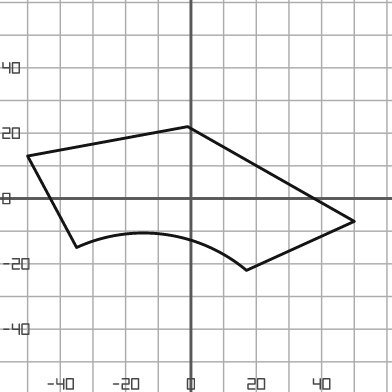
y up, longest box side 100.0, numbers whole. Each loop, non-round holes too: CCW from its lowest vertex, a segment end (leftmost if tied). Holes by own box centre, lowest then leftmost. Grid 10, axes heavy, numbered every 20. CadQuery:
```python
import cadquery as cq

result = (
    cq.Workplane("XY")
    .moveTo(17.0, -22.0)
    .lineTo(50.0, -7.0)
    .lineTo(-1.0, 22.0)
    .lineTo(-50.0, 13.0)
    .lineTo(-35.0, -15.0)
    .threePointArc((-8.0, -11.0), (17.0, -22.0))
    .close()
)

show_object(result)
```